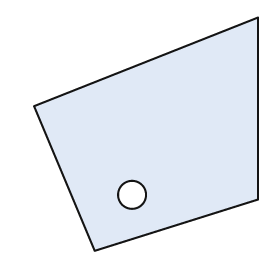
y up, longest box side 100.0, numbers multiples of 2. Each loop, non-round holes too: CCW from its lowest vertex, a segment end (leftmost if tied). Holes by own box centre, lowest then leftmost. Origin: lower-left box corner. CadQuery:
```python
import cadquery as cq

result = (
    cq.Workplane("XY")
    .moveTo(26.0, 0.0)
    .lineTo(96.0, 22.0)
    .lineTo(96.0, 100.0)
    .lineTo(0.0, 62.0)
    .close()
    .moveTo(42.0, 24.0)
    .circle(6.0)
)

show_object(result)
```